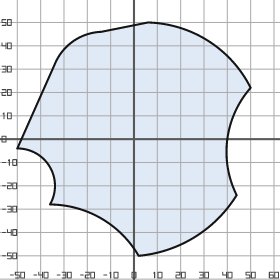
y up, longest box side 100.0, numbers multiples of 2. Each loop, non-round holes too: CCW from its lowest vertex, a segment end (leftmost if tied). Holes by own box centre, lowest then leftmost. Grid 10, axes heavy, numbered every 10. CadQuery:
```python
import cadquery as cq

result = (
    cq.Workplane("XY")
    .moveTo(2.0, -50.0)
    .threePointArc((26.0, -42.0), (44.0, -24.0))
    .threePointArc((40.0, 0.0), (50.0, 22.0))
    .threePointArc((32.0, 42.0), (6.0, 50.0))
    .lineTo(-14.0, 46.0)
    .threePointArc((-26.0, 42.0), (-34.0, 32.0))
    .lineTo(-50.0, -4.0)
    .threePointArc((-36.0, -12.0), (-36.0, -28.0))
    .threePointArc((-14.0, -34.0), (2.0, -50.0))
    .close()
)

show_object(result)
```